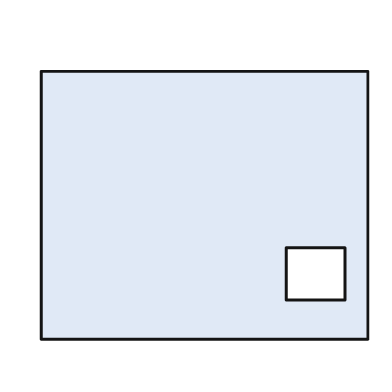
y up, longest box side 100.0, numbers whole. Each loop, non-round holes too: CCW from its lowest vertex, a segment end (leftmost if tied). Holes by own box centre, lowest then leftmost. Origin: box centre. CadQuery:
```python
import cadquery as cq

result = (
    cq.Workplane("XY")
    .moveTo(-50.0, -41.0)
    .lineTo(50.0, -41.0)
    .lineTo(50.0, 41.0)
    .lineTo(-50.0, 41.0)
    .close()
    .moveTo(25.0, -29.0)
    .lineTo(43.0, -29.0)
    .lineTo(43.0, -13.0)
    .lineTo(25.0, -13.0)
    .close()
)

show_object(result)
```